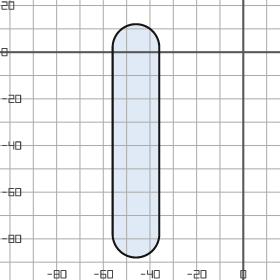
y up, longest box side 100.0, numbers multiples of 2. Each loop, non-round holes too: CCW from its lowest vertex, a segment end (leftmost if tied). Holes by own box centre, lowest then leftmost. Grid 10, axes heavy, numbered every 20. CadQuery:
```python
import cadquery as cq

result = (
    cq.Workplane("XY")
    .moveTo(-56.0, -78.0)
    .threePointArc((-46.0, -88.0), (-36.0, -78.0))
    .lineTo(-36.0, 2.0)
    .threePointArc((-46.0, 12.0), (-56.0, 2.0))
    .close()
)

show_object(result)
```